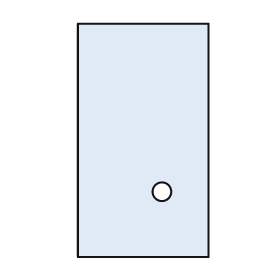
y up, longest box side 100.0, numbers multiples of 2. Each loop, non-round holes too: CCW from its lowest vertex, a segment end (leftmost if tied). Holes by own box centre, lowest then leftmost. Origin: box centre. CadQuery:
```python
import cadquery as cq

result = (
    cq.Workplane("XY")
    .moveTo(-28.0, -50.0)
    .lineTo(28.0, -50.0)
    .lineTo(28.0, 50.0)
    .lineTo(-28.0, 50.0)
    .close()
    .moveTo(8.0, -22.0)
    .circle(4.0)
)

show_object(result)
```